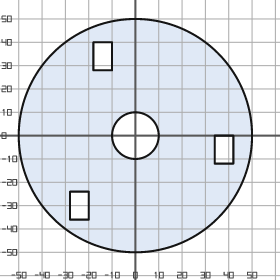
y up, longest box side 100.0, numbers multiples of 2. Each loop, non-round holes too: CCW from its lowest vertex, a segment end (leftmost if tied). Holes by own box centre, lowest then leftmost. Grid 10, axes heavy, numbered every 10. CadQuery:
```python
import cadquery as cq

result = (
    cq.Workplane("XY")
    .moveTo(0.0, 0.0)
    .circle(50.0)
    .moveTo(-28.0, -36.0)
    .lineTo(-20.0, -36.0)
    .lineTo(-20.0, -24.0)
    .lineTo(-28.0, -24.0)
    .close()
    .moveTo(34.0, -12.0)
    .lineTo(42.0, -12.0)
    .lineTo(42.0, 0.0)
    .lineTo(34.0, 0.0)
    .close()
    .moveTo(0.0, 0.0)
    .circle(10.0)
    .moveTo(-18.0, 28.0)
    .lineTo(-10.0, 28.0)
    .lineTo(-10.0, 40.0)
    .lineTo(-18.0, 40.0)
    .close()
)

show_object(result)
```